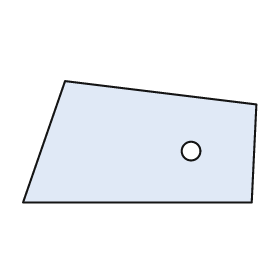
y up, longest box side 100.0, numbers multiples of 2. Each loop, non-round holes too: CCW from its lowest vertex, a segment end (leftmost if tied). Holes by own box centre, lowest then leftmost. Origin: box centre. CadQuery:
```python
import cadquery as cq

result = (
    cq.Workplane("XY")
    .moveTo(-50.0, -26.0)
    .lineTo(48.0, -26.0)
    .lineTo(50.0, 16.0)
    .lineTo(-32.0, 26.0)
    .close()
    .moveTo(22.0, -4.0)
    .circle(4.0)
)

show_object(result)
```